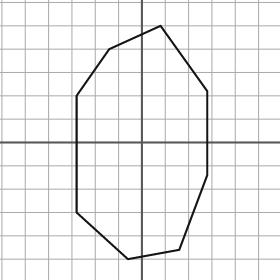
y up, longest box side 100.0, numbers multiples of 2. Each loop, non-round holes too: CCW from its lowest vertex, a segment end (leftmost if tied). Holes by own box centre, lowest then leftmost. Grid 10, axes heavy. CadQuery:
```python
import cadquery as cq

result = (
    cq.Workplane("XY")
    .moveTo(-6.0, -50.0)
    .lineTo(16.0, -46.0)
    .lineTo(28.0, -14.0)
    .lineTo(28.0, 22.0)
    .lineTo(8.0, 50.0)
    .lineTo(-14.0, 40.0)
    .lineTo(-28.0, 20.0)
    .lineTo(-28.0, -30.0)
    .close()
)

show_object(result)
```